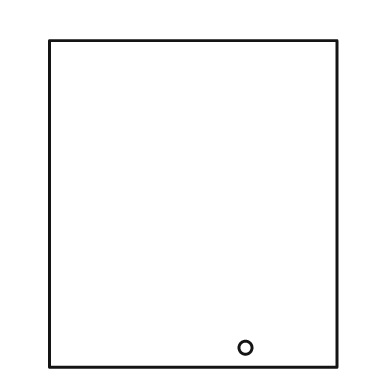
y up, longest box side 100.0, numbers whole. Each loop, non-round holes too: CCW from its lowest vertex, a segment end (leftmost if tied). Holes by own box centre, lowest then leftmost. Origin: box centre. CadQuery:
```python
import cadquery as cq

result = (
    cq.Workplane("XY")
    .moveTo(-44.0, -50.0)
    .lineTo(44.0, -50.0)
    .lineTo(44.0, 50.0)
    .lineTo(-44.0, 50.0)
    .close()
    .moveTo(16.0, -44.0)
    .circle(2.0)
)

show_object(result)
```